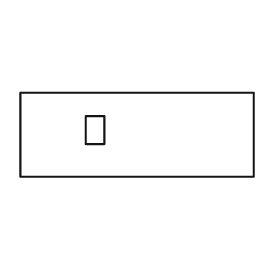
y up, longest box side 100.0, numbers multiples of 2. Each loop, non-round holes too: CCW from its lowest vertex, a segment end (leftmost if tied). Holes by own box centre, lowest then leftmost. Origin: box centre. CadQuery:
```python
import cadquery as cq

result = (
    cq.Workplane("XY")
    .moveTo(-50.0, -18.0)
    .lineTo(50.0, -18.0)
    .lineTo(50.0, 18.0)
    .lineTo(-50.0, 18.0)
    .close()
    .moveTo(-22.0, -4.0)
    .lineTo(-14.0, -4.0)
    .lineTo(-14.0, 8.0)
    .lineTo(-22.0, 8.0)
    .close()
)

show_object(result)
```